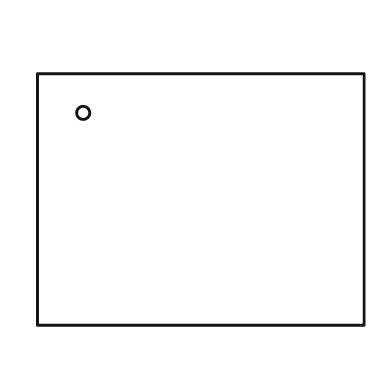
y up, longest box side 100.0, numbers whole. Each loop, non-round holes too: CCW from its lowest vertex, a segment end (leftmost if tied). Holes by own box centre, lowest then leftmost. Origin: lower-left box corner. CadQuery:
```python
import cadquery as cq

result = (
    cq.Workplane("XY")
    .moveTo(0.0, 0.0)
    .lineTo(100.0, 0.0)
    .lineTo(100.0, 77.0)
    .lineTo(0.0, 77.0)
    .close()
    .moveTo(14.0, 65.0)
    .circle(2.0)
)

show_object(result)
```